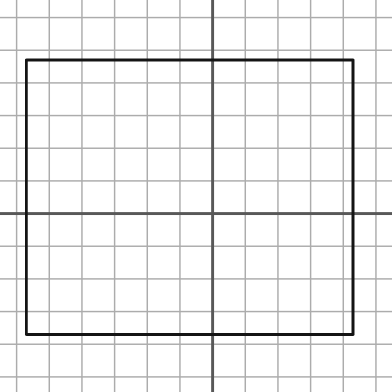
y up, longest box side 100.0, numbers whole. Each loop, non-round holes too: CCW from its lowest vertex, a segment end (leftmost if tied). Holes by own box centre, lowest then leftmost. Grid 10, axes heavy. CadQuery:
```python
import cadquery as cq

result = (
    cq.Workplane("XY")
    .moveTo(-57.0, -37.0)
    .lineTo(43.0, -37.0)
    .lineTo(43.0, 47.0)
    .lineTo(-57.0, 47.0)
    .close()
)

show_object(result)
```